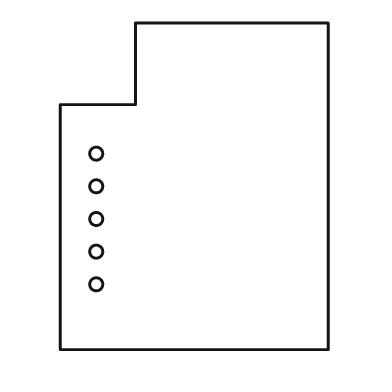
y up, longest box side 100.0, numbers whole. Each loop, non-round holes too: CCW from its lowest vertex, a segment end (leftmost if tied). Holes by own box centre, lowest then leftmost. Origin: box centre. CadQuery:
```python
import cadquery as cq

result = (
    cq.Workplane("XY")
    .moveTo(-41.0, -50.0)
    .lineTo(41.0, -50.0)
    .lineTo(41.0, 50.0)
    .lineTo(-18.0, 50.0)
    .lineTo(-18.0, 25.0)
    .lineTo(-41.0, 25.0)
    .close()
    .moveTo(-30.0, -30.0)
    .circle(2.0)
    .moveTo(-30.0, -20.0)
    .circle(2.0)
    .moveTo(-30.0, -10.0)
    .circle(2.0)
    .moveTo(-30.0, 0.0)
    .circle(2.0)
    .moveTo(-30.0, 10.0)
    .circle(2.0)
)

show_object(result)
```